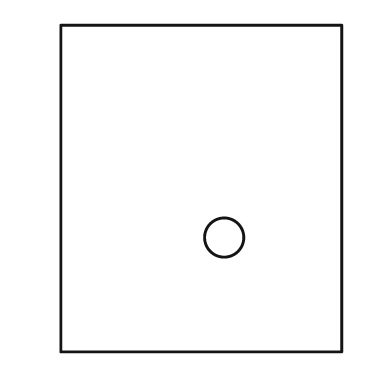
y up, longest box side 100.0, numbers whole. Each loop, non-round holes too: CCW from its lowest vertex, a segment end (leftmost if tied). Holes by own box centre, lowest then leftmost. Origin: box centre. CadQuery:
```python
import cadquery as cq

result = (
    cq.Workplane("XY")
    .moveTo(-43.0, -50.0)
    .lineTo(43.0, -50.0)
    .lineTo(43.0, 50.0)
    .lineTo(-43.0, 50.0)
    .close()
    .moveTo(7.0, -15.0)
    .circle(6.0)
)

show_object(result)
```